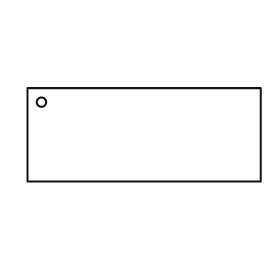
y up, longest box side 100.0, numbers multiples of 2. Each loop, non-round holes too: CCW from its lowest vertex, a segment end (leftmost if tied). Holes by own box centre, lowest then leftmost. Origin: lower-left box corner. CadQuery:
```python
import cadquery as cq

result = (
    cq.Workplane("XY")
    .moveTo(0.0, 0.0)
    .lineTo(100.0, 0.0)
    .lineTo(100.0, 40.0)
    .lineTo(0.0, 40.0)
    .close()
    .moveTo(6.0, 34.0)
    .circle(2.0)
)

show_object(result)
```